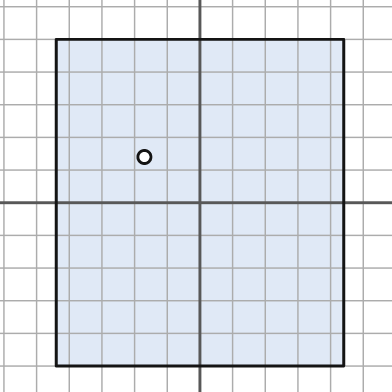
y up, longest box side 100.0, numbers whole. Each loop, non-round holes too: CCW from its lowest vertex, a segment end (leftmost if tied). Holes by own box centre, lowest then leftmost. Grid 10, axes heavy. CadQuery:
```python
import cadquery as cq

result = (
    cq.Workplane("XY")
    .moveTo(-44.0, -50.0)
    .lineTo(44.0, -50.0)
    .lineTo(44.0, 50.0)
    .lineTo(-44.0, 50.0)
    .close()
    .moveTo(-17.0, 14.0)
    .circle(2.0)
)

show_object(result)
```